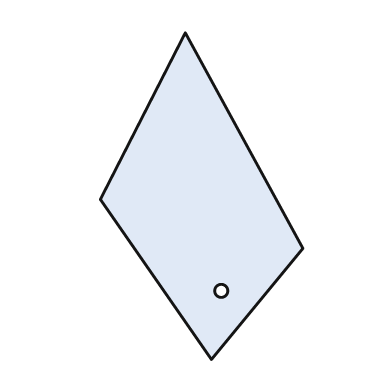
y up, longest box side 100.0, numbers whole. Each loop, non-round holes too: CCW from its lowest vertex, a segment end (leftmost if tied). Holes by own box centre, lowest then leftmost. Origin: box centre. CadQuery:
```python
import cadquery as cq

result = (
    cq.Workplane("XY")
    .moveTo(3.0, -50.0)
    .lineTo(31.0, -16.0)
    .lineTo(-5.0, 50.0)
    .lineTo(-31.0, -1.0)
    .close()
    .moveTo(6.0, -29.0)
    .circle(2.0)
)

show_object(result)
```